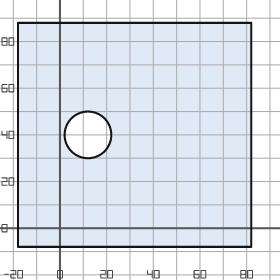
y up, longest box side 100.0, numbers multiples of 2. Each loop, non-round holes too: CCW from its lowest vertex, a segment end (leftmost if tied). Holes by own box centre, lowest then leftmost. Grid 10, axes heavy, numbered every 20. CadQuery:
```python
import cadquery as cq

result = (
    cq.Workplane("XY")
    .moveTo(-18.0, -8.0)
    .lineTo(82.0, -8.0)
    .lineTo(82.0, 88.0)
    .lineTo(-18.0, 88.0)
    .close()
    .moveTo(12.0, 40.0)
    .circle(10.0)
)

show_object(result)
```